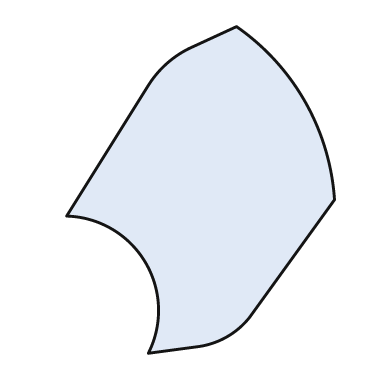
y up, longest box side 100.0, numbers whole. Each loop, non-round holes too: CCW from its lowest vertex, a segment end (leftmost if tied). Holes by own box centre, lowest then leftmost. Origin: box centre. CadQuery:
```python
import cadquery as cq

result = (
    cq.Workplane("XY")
    .moveTo(-16.0, -50.0)
    .lineTo(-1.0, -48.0)
    .threePointArc((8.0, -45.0), (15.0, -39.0))
    .lineTo(41.0, -3.0)
    .threePointArc((32.0, 27.0), (11.0, 50.0))
    .lineTo(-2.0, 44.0)
    .threePointArc((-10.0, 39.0), (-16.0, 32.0))
    .lineTo(-41.0, -8.0)
    .threePointArc((-17.0, -22.0), (-16.0, -50.0))
    .close()
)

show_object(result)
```